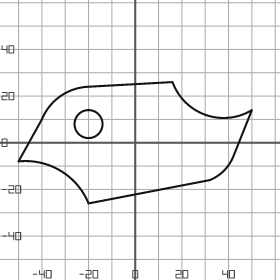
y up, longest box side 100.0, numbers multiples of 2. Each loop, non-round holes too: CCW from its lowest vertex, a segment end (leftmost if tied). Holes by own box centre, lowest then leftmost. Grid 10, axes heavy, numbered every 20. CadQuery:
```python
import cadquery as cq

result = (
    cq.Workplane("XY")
    .moveTo(-20.0, -26.0)
    .lineTo(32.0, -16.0)
    .threePointArc((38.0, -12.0), (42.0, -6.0))
    .lineTo(50.0, 14.0)
    .threePointArc((30.0, 12.0), (16.0, 26.0))
    .lineTo(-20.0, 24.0)
    .threePointArc((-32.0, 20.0), (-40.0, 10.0))
    .lineTo(-50.0, -8.0)
    .threePointArc((-32.0, -12.0), (-20.0, -26.0))
    .close()
    .moveTo(-20.0, 8.0)
    .circle(6.0)
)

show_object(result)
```